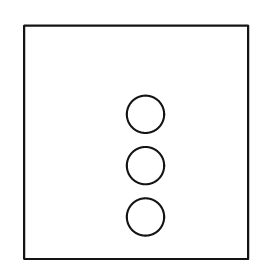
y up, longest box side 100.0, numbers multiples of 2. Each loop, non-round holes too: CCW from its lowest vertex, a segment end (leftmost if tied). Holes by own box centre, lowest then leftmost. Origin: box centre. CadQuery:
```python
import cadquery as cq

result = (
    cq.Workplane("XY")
    .moveTo(-48.0, -50.0)
    .lineTo(48.0, -50.0)
    .lineTo(48.0, 50.0)
    .lineTo(-48.0, 50.0)
    .close()
    .moveTo(4.0, -32.0)
    .circle(8.0)
    .moveTo(4.0, -10.0)
    .circle(8.0)
    .moveTo(4.0, 12.0)
    .circle(8.0)
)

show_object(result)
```